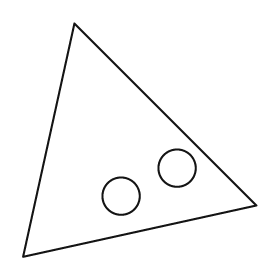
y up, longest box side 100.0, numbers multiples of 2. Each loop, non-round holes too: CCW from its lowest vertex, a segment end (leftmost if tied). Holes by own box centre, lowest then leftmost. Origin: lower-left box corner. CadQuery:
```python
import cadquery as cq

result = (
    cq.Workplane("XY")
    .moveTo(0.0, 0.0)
    .lineTo(100.0, 22.0)
    .lineTo(22.0, 100.0)
    .close()
    .moveTo(42.0, 26.0)
    .circle(8.0)
    .moveTo(66.0, 38.0)
    .circle(8.0)
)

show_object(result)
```